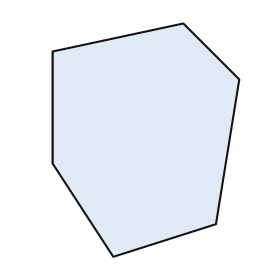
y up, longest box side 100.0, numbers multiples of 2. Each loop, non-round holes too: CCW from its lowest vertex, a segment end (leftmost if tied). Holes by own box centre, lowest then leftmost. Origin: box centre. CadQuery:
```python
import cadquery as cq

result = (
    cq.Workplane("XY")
    .moveTo(-14.0, -50.0)
    .lineTo(30.0, -36.0)
    .lineTo(40.0, 26.0)
    .lineTo(16.0, 50.0)
    .lineTo(-40.0, 38.0)
    .lineTo(-40.0, -10.0)
    .close()
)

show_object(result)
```